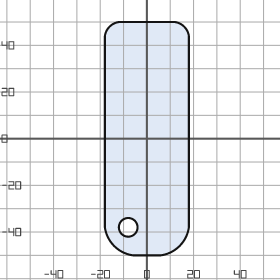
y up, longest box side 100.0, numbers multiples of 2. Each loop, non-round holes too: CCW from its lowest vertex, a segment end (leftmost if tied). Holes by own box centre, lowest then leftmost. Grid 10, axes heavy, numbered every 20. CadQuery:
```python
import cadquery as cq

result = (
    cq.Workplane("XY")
    .moveTo(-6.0, -50.0)
    .lineTo(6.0, -50.0)
    .threePointArc((14.0, -46.0), (18.0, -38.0))
    .lineTo(18.0, 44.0)
    .threePointArc((16.0, 48.0), (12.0, 50.0))
    .lineTo(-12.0, 50.0)
    .threePointArc((-16.0, 48.0), (-18.0, 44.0))
    .lineTo(-18.0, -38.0)
    .threePointArc((-14.0, -46.0), (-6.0, -50.0))
    .close()
    .moveTo(-8.0, -38.0)
    .circle(4.0)
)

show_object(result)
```